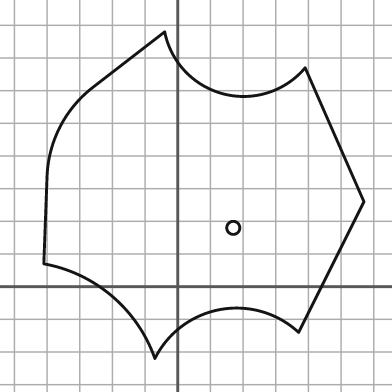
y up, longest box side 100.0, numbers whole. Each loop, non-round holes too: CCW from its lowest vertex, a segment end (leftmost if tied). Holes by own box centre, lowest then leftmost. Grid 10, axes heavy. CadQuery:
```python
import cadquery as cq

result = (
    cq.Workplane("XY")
    .moveTo(-7.0, -22.0)
    .threePointArc((13.0, -7.0), (37.0, -14.0))
    .lineTo(57.0, 26.0)
    .lineTo(39.0, 67.0)
    .threePointArc((14.0, 59.0), (-4.0, 78.0))
    .lineTo(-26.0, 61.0)
    .threePointArc((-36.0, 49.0), (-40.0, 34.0))
    .lineTo(-41.0, 7.0)
    .threePointArc((-20.0, -3.0), (-7.0, -22.0))
    .close()
    .moveTo(17.0, 18.0)
    .circle(2.0)
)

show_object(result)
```